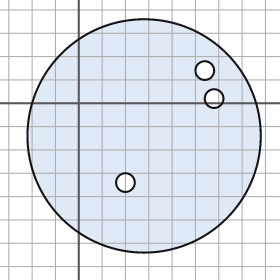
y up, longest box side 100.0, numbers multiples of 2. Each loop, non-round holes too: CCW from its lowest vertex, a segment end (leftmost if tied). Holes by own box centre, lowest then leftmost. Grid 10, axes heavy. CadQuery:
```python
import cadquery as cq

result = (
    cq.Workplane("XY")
    .moveTo(28.0, -14.0)
    .circle(50.0)
    .moveTo(20.0, -34.0)
    .circle(4.0)
    .moveTo(58.0, 2.0)
    .circle(4.0)
    .moveTo(54.0, 14.0)
    .circle(4.0)
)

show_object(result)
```